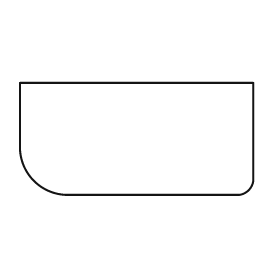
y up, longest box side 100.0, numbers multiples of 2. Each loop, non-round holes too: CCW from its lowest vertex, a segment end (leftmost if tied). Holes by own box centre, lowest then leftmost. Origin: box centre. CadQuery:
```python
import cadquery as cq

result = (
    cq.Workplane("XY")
    .moveTo(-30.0, -24.0)
    .lineTo(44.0, -24.0)
    .threePointArc((48.0, -22.0), (50.0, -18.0))
    .lineTo(50.0, 24.0)
    .lineTo(-50.0, 24.0)
    .lineTo(-50.0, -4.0)
    .threePointArc((-44.0, -18.0), (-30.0, -24.0))
    .close()
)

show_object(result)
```